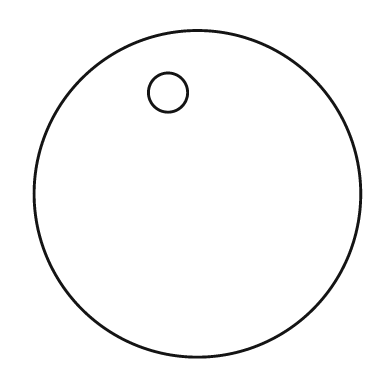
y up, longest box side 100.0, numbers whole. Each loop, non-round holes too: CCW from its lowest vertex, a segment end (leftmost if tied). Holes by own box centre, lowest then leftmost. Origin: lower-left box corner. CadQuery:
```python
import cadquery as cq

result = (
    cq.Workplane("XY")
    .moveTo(50.0, 50.0)
    .circle(50.0)
    .moveTo(41.0, 81.0)
    .circle(6.0)
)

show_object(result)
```